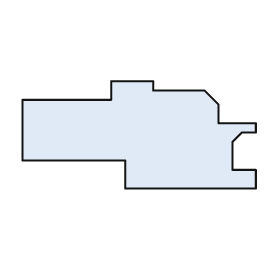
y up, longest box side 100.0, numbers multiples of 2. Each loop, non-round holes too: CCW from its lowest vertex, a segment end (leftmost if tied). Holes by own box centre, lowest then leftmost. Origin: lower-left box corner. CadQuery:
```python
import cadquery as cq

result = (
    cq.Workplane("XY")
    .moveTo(44.0, 0.0)
    .lineTo(100.0, 0.0)
    .lineTo(100.0, 8.0)
    .lineTo(90.0, 8.0)
    .lineTo(90.0, 20.0)
    .lineTo(94.0, 24.0)
    .lineTo(100.0, 24.0)
    .lineTo(100.0, 28.0)
    .lineTo(84.0, 28.0)
    .lineTo(84.0, 36.0)
    .lineTo(78.0, 42.0)
    .lineTo(56.0, 42.0)
    .lineTo(56.0, 46.0)
    .lineTo(38.0, 46.0)
    .lineTo(38.0, 38.0)
    .lineTo(0.0, 38.0)
    .lineTo(0.0, 12.0)
    .lineTo(44.0, 12.0)
    .close()
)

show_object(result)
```